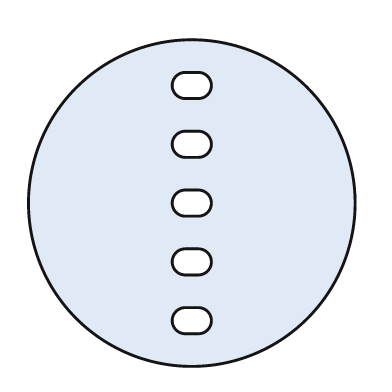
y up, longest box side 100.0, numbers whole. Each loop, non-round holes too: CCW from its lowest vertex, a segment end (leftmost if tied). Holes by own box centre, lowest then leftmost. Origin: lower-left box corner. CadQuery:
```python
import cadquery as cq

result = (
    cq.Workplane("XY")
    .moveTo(50.0, 50.0)
    .circle(50.0)
    .moveTo(48.0, 10.0)
    .lineTo(52.0, 10.0)
    .threePointArc((56.0, 14.0), (52.0, 18.0))
    .lineTo(48.0, 18.0)
    .threePointArc((44.0, 14.0), (48.0, 10.0))
    .close()
    .moveTo(48.0, 28.0)
    .lineTo(52.0, 28.0)
    .threePointArc((56.0, 32.0), (52.0, 36.0))
    .lineTo(48.0, 36.0)
    .threePointArc((44.0, 32.0), (48.0, 28.0))
    .close()
    .moveTo(48.0, 46.0)
    .lineTo(52.0, 46.0)
    .threePointArc((56.0, 50.0), (52.0, 54.0))
    .lineTo(48.0, 54.0)
    .threePointArc((44.0, 50.0), (48.0, 46.0))
    .close()
    .moveTo(48.0, 64.0)
    .lineTo(52.0, 64.0)
    .threePointArc((56.0, 68.0), (52.0, 72.0))
    .lineTo(48.0, 72.0)
    .threePointArc((44.0, 68.0), (48.0, 64.0))
    .close()
    .moveTo(48.0, 82.0)
    .lineTo(52.0, 82.0)
    .threePointArc((56.0, 86.0), (52.0, 90.0))
    .lineTo(48.0, 90.0)
    .threePointArc((44.0, 86.0), (48.0, 82.0))
    .close()
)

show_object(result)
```